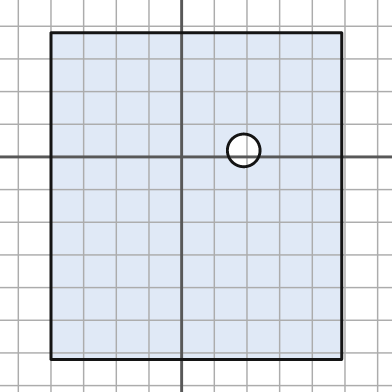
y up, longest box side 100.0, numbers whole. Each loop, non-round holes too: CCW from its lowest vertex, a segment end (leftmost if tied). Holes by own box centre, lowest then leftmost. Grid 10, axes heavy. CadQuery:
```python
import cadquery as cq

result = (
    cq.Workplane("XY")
    .moveTo(-40.0, -62.0)
    .lineTo(49.0, -62.0)
    .lineTo(49.0, 38.0)
    .lineTo(-40.0, 38.0)
    .close()
    .moveTo(19.0, 2.0)
    .circle(5.0)
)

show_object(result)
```